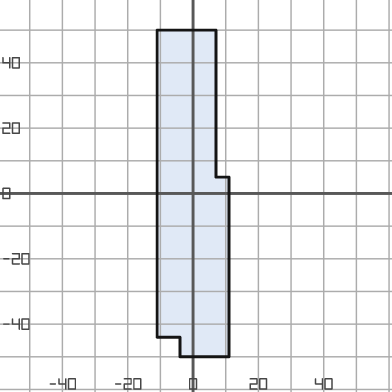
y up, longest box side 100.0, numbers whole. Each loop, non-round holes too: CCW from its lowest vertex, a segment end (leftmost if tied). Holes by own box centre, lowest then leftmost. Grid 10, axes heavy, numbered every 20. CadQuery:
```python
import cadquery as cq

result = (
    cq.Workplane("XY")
    .moveTo(-4.0, -50.0)
    .lineTo(11.0, -50.0)
    .lineTo(11.0, 5.0)
    .lineTo(7.0, 5.0)
    .lineTo(7.0, 50.0)
    .lineTo(-11.0, 50.0)
    .lineTo(-11.0, -44.0)
    .lineTo(-4.0, -44.0)
    .close()
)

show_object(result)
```